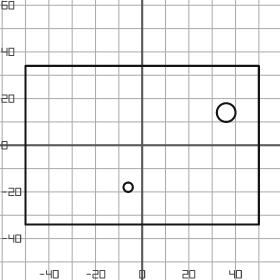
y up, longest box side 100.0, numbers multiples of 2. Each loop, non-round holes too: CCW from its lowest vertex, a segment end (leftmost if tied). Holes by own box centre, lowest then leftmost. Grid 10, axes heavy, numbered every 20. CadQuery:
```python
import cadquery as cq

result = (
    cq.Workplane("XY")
    .moveTo(-50.0, -34.0)
    .lineTo(50.0, -34.0)
    .lineTo(50.0, 34.0)
    .lineTo(-50.0, 34.0)
    .close()
    .moveTo(-6.0, -18.0)
    .circle(2.0)
    .moveTo(36.0, 14.0)
    .circle(4.0)
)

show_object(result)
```